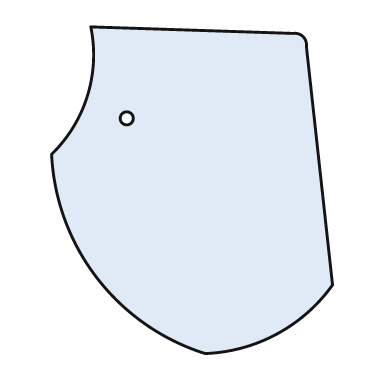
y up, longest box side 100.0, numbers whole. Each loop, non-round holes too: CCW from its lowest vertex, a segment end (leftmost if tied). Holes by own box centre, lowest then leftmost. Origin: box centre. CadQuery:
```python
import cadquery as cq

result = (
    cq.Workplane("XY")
    .moveTo(4.0, -50.0)
    .threePointArc((26.0, -44.0), (43.0, -29.0))
    .lineTo(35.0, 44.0)
    .threePointArc((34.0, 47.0), (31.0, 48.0))
    .lineTo(-31.0, 50.0)
    .threePointArc((-32.0, 29.0), (-43.0, 11.0))
    .threePointArc((-29.0, -27.0), (4.0, -50.0))
    .close()
    .moveTo(-20.0, 22.0)
    .circle(2.0)
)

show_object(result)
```